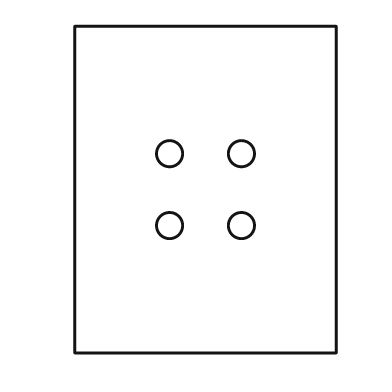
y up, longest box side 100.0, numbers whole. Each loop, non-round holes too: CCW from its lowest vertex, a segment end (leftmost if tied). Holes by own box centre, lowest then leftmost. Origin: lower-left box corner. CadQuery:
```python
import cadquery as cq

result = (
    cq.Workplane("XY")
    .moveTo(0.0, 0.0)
    .lineTo(80.0, 0.0)
    .lineTo(80.0, 100.0)
    .lineTo(0.0, 100.0)
    .close()
    .moveTo(29.0, 39.0)
    .circle(4.0)
    .moveTo(51.0, 39.0)
    .circle(4.0)
    .moveTo(29.0, 61.0)
    .circle(4.0)
    .moveTo(51.0, 61.0)
    .circle(4.0)
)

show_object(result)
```